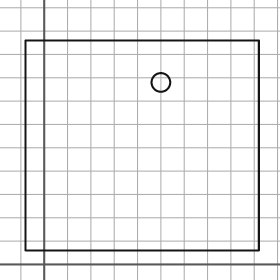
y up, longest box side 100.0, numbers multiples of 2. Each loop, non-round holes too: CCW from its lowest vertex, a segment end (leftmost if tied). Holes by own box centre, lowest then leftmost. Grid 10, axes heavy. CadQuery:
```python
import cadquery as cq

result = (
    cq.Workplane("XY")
    .moveTo(-8.0, 6.0)
    .lineTo(92.0, 6.0)
    .lineTo(92.0, 96.0)
    .lineTo(-8.0, 96.0)
    .close()
    .moveTo(50.0, 78.0)
    .circle(4.0)
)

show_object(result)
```